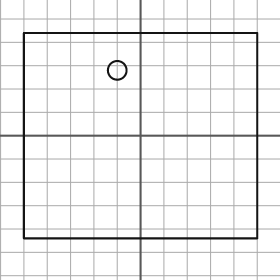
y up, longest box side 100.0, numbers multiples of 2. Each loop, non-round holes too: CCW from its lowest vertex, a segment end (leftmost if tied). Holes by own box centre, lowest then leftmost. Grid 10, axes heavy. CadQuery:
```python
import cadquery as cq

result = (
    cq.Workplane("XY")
    .moveTo(-50.0, -44.0)
    .lineTo(50.0, -44.0)
    .lineTo(50.0, 44.0)
    .lineTo(-50.0, 44.0)
    .close()
    .moveTo(-10.0, 28.0)
    .circle(4.0)
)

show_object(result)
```